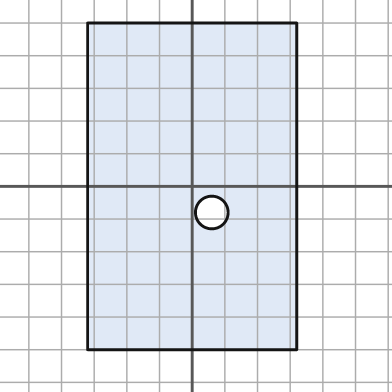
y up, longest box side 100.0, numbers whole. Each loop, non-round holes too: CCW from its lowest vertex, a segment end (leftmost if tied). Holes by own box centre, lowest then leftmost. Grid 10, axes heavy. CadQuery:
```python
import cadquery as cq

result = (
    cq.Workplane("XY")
    .moveTo(-32.0, -50.0)
    .lineTo(32.0, -50.0)
    .lineTo(32.0, 50.0)
    .lineTo(-32.0, 50.0)
    .close()
    .moveTo(6.0, -8.0)
    .circle(5.0)
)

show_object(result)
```